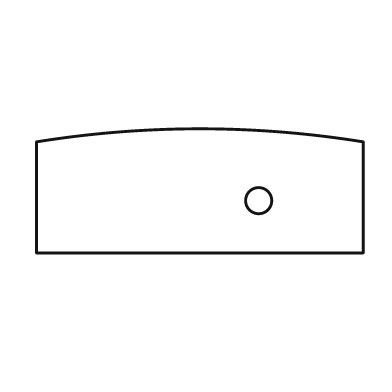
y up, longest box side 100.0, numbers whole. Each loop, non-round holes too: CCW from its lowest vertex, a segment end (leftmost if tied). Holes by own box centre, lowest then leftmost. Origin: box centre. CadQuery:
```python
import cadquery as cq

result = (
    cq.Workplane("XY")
    .moveTo(-50.0, -19.0)
    .lineTo(50.0, -19.0)
    .lineTo(50.0, 15.0)
    .threePointArc((0.0, 19.0), (-50.0, 15.0))
    .close()
    .moveTo(18.0, -3.0)
    .circle(4.0)
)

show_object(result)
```